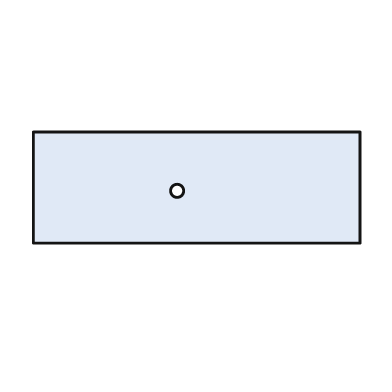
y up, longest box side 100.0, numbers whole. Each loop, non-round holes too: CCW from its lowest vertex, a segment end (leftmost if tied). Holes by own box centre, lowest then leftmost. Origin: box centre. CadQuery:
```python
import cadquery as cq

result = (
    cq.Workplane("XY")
    .moveTo(-50.0, -17.0)
    .lineTo(50.0, -17.0)
    .lineTo(50.0, 17.0)
    .lineTo(-50.0, 17.0)
    .close()
    .moveTo(-6.0, -1.0)
    .circle(2.0)
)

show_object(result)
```